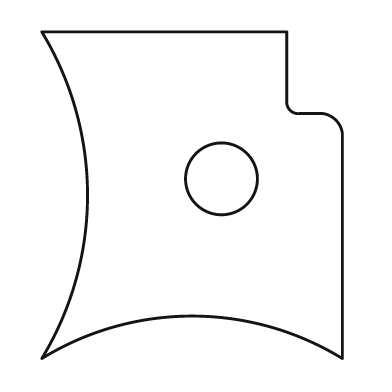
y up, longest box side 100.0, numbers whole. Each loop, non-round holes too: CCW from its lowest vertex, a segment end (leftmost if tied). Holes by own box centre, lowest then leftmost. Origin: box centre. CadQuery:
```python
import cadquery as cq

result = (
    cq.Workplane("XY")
    .moveTo(-46.0, -50.0)
    .threePointArc((0.0, -37.0), (46.0, -50.0))
    .lineTo(46.0, 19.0)
    .threePointArc((44.0, 23.0), (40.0, 25.0))
    .lineTo(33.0, 25.0)
    .threePointArc((30.0, 26.0), (29.0, 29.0))
    .lineTo(29.0, 50.0)
    .lineTo(-46.0, 50.0)
    .threePointArc((-32.0, 0.0), (-46.0, -50.0))
    .close()
    .moveTo(9.0, 5.0)
    .circle(11.0)
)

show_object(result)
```